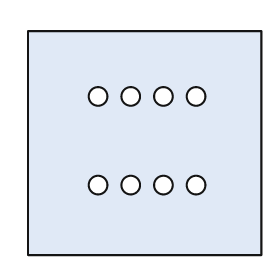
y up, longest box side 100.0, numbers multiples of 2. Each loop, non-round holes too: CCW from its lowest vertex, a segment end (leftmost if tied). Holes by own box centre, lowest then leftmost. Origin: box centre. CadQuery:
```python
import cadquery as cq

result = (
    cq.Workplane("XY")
    .moveTo(-50.0, -48.0)
    .lineTo(50.0, -48.0)
    .lineTo(50.0, 48.0)
    .lineTo(-50.0, 48.0)
    .close()
    .moveTo(-20.0, -18.0)
    .circle(4.0)
    .moveTo(-6.0, -18.0)
    .circle(4.0)
    .moveTo(8.0, -18.0)
    .circle(4.0)
    .moveTo(22.0, -18.0)
    .circle(4.0)
    .moveTo(-20.0, 20.0)
    .circle(4.0)
    .moveTo(-6.0, 20.0)
    .circle(4.0)
    .moveTo(8.0, 20.0)
    .circle(4.0)
    .moveTo(22.0, 20.0)
    .circle(4.0)
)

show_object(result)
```